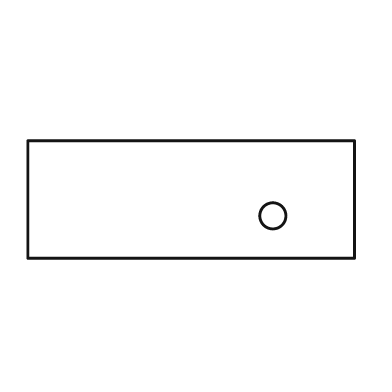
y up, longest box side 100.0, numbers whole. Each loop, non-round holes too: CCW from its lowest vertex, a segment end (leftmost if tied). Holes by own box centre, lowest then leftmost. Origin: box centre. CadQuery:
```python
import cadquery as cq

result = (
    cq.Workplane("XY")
    .moveTo(-50.0, -18.0)
    .lineTo(50.0, -18.0)
    .lineTo(50.0, 18.0)
    .lineTo(-50.0, 18.0)
    .close()
    .moveTo(25.0, -5.0)
    .circle(4.0)
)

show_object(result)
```